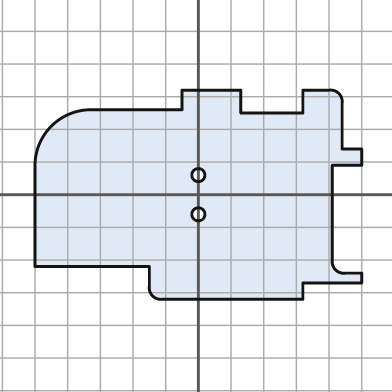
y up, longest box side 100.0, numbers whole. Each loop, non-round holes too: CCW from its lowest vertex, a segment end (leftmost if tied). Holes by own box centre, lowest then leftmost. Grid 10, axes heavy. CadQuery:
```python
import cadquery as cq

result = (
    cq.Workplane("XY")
    .moveTo(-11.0, -32.0)
    .lineTo(32.0, -32.0)
    .lineTo(32.0, -27.0)
    .lineTo(50.0, -27.0)
    .lineTo(50.0, -24.0)
    .lineTo(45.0, -24.0)
    .threePointArc((42.0, -23.0), (41.0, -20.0))
    .lineTo(41.0, 9.0)
    .lineTo(50.0, 9.0)
    .lineTo(50.0, 14.0)
    .lineTo(44.0, 14.0)
    .lineTo(44.0, 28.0)
    .threePointArc((43.0, 31.0), (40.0, 32.0))
    .lineTo(32.0, 32.0)
    .lineTo(32.0, 25.0)
    .lineTo(13.0, 25.0)
    .lineTo(13.0, 32.0)
    .lineTo(-5.0, 32.0)
    .lineTo(-5.0, 26.0)
    .lineTo(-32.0, 26.0)
    .threePointArc((-45.0, 21.0), (-50.0, 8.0))
    .lineTo(-50.0, -22.0)
    .lineTo(-15.0, -22.0)
    .lineTo(-15.0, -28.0)
    .threePointArc((-14.0, -31.0), (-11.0, -32.0))
    .close()
    .moveTo(0.0, -6.0)
    .circle(2.0)
    .moveTo(0.0, 6.0)
    .circle(2.0)
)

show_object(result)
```